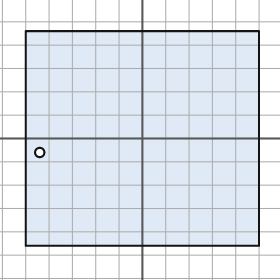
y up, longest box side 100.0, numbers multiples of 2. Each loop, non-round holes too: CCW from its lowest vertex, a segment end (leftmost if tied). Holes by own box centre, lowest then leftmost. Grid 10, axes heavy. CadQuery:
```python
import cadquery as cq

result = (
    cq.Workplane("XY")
    .moveTo(-50.0, -46.0)
    .lineTo(50.0, -46.0)
    .lineTo(50.0, 46.0)
    .lineTo(-50.0, 46.0)
    .close()
    .moveTo(-44.0, -6.0)
    .circle(2.0)
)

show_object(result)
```